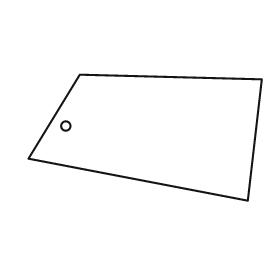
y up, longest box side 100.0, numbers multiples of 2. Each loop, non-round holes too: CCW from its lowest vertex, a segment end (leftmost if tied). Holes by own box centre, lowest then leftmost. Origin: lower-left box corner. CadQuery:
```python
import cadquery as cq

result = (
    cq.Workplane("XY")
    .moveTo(94.0, 0.0)
    .lineTo(100.0, 52.0)
    .lineTo(22.0, 54.0)
    .lineTo(0.0, 18.0)
    .close()
    .moveTo(16.0, 32.0)
    .circle(2.0)
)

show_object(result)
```